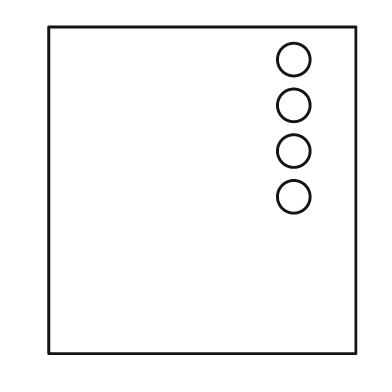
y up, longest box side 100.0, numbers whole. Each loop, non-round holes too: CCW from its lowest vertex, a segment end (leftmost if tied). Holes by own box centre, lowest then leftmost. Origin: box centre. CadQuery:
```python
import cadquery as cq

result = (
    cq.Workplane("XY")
    .moveTo(-47.0, -50.0)
    .lineTo(47.0, -50.0)
    .lineTo(47.0, 50.0)
    .lineTo(-47.0, 50.0)
    .close()
    .moveTo(28.0, -2.0)
    .circle(5.0)
    .moveTo(28.0, 12.0)
    .circle(5.0)
    .moveTo(28.0, 26.0)
    .circle(5.0)
    .moveTo(28.0, 40.0)
    .circle(5.0)
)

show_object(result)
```